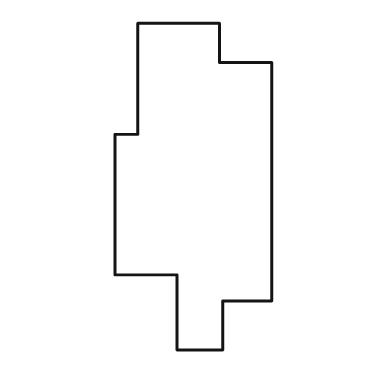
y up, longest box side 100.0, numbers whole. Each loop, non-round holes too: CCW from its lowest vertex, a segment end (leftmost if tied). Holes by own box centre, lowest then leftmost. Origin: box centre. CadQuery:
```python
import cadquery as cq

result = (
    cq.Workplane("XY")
    .moveTo(-5.0, -50.0)
    .lineTo(9.0, -50.0)
    .lineTo(9.0, -35.0)
    .lineTo(24.0, -35.0)
    .lineTo(24.0, 38.0)
    .lineTo(8.0, 38.0)
    .lineTo(8.0, 50.0)
    .lineTo(-17.0, 50.0)
    .lineTo(-17.0, 16.0)
    .lineTo(-24.0, 16.0)
    .lineTo(-24.0, -27.0)
    .lineTo(-5.0, -27.0)
    .close()
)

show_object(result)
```